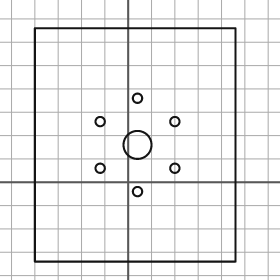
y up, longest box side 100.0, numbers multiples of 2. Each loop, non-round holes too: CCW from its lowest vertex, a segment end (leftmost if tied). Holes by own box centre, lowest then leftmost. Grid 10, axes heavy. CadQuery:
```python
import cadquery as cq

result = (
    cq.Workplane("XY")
    .moveTo(-40.0, -34.0)
    .lineTo(46.0, -34.0)
    .lineTo(46.0, 66.0)
    .lineTo(-40.0, 66.0)
    .close()
    .moveTo(4.0, -4.0)
    .circle(2.0)
    .moveTo(-12.0, 6.0)
    .circle(2.0)
    .moveTo(20.0, 6.0)
    .circle(2.0)
    .moveTo(4.0, 16.0)
    .circle(6.0)
    .moveTo(-12.0, 26.0)
    .circle(2.0)
    .moveTo(20.0, 26.0)
    .circle(2.0)
    .moveTo(4.0, 36.0)
    .circle(2.0)
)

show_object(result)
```